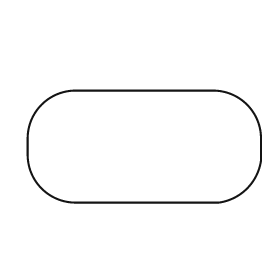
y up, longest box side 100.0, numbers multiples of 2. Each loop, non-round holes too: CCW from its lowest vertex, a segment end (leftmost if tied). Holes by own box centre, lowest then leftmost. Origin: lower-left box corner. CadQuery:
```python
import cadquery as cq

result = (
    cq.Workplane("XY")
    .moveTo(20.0, 0.0)
    .lineTo(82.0, 0.0)
    .threePointArc((94.0, 6.0), (100.0, 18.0))
    .lineTo(100.0, 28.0)
    .threePointArc((94.0, 42.0), (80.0, 48.0))
    .lineTo(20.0, 48.0)
    .threePointArc((6.0, 42.0), (0.0, 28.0))
    .lineTo(0.0, 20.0)
    .threePointArc((6.0, 6.0), (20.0, 0.0))
    .close()
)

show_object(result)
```